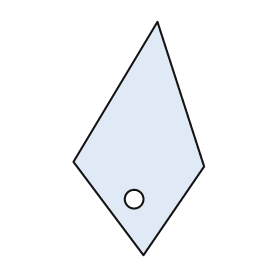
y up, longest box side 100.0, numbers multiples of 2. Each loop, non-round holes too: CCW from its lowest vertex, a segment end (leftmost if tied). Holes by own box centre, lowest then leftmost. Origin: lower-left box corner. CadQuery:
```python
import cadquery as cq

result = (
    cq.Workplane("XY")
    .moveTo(30.0, 0.0)
    .lineTo(56.0, 38.0)
    .lineTo(36.0, 100.0)
    .lineTo(0.0, 40.0)
    .close()
    .moveTo(26.0, 24.0)
    .circle(4.0)
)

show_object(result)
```